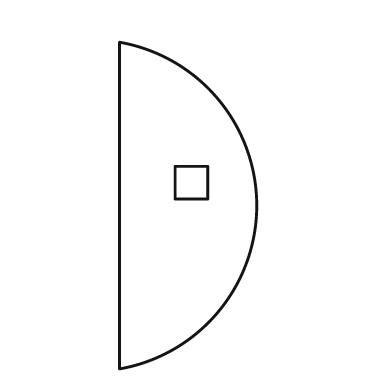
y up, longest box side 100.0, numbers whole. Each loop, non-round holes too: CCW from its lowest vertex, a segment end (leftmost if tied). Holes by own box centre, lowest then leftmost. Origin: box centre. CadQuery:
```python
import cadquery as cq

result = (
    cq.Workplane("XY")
    .moveTo(-21.0, -50.0)
    .threePointArc((21.0, 0.0), (-21.0, 50.0))
    .close()
    .moveTo(-4.0, 2.0)
    .lineTo(6.0, 2.0)
    .lineTo(6.0, 12.0)
    .lineTo(-4.0, 12.0)
    .close()
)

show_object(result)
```